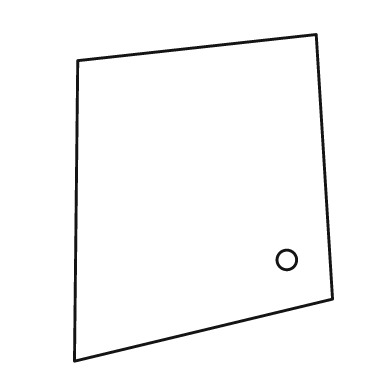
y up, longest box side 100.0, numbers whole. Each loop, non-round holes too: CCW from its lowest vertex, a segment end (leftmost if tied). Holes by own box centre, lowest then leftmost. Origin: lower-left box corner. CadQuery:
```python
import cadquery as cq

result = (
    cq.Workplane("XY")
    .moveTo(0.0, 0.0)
    .lineTo(79.0, 19.0)
    .lineTo(74.0, 100.0)
    .lineTo(1.0, 92.0)
    .close()
    .moveTo(65.0, 31.0)
    .circle(3.0)
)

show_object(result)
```